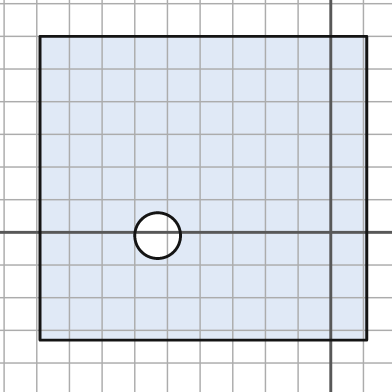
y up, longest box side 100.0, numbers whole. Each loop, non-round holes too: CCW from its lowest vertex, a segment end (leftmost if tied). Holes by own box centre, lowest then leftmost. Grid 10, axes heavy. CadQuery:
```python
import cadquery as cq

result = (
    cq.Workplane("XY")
    .moveTo(-89.0, -33.0)
    .lineTo(11.0, -33.0)
    .lineTo(11.0, 60.0)
    .lineTo(-89.0, 60.0)
    .close()
    .moveTo(-53.0, -1.0)
    .circle(7.0)
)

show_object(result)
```